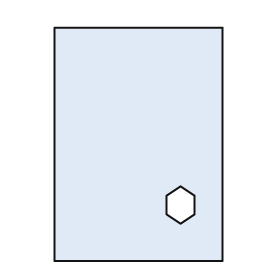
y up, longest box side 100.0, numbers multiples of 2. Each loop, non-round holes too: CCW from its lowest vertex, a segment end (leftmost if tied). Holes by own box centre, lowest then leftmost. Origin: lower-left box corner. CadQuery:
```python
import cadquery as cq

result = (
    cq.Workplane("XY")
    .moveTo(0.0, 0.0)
    .lineTo(72.0, 0.0)
    .lineTo(72.0, 100.0)
    .lineTo(0.0, 100.0)
    .close()
    .moveTo(54.0, 16.0)
    .lineTo(60.0, 20.0)
    .lineTo(60.0, 28.0)
    .lineTo(54.0, 32.0)
    .lineTo(48.0, 28.0)
    .lineTo(48.0, 20.0)
    .close()
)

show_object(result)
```